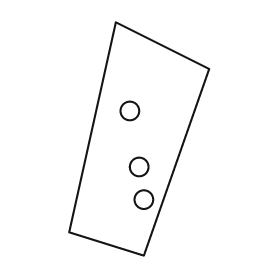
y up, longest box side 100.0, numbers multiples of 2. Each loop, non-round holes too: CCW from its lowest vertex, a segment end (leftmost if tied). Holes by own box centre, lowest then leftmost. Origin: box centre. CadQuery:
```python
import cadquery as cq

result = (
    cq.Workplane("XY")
    .moveTo(2.0, -50.0)
    .lineTo(30.0, 30.0)
    .lineTo(-10.0, 50.0)
    .lineTo(-30.0, -40.0)
    .close()
    .moveTo(2.0, -26.0)
    .circle(4.0)
    .moveTo(0.0, -12.0)
    .circle(4.0)
    .moveTo(-4.0, 12.0)
    .circle(4.0)
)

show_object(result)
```